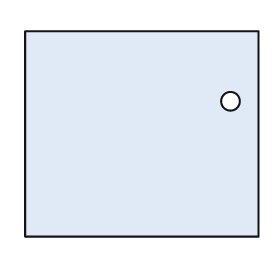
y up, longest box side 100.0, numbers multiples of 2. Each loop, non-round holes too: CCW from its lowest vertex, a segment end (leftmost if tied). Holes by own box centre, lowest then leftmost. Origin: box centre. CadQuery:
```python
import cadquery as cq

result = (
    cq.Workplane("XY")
    .moveTo(-50.0, -44.0)
    .lineTo(50.0, -44.0)
    .lineTo(50.0, 44.0)
    .lineTo(-50.0, 44.0)
    .close()
    .moveTo(38.0, 14.0)
    .circle(4.0)
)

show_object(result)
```